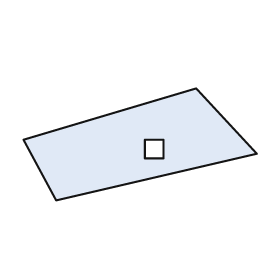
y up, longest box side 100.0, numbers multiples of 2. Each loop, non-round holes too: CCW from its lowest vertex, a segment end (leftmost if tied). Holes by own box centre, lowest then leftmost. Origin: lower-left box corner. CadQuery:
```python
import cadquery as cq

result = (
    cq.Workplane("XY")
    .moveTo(14.0, 0.0)
    .lineTo(100.0, 20.0)
    .lineTo(74.0, 48.0)
    .lineTo(0.0, 26.0)
    .close()
    .moveTo(52.0, 18.0)
    .lineTo(60.0, 18.0)
    .lineTo(60.0, 26.0)
    .lineTo(52.0, 26.0)
    .close()
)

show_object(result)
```